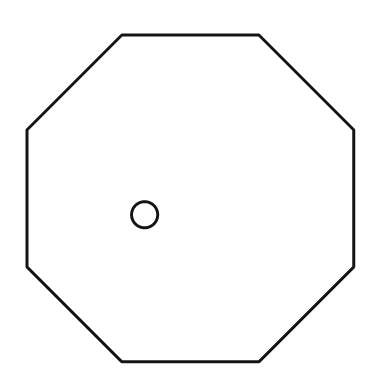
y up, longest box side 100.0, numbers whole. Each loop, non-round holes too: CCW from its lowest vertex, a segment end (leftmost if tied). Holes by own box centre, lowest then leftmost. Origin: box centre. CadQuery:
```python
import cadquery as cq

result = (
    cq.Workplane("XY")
    .moveTo(-21.0, -50.0)
    .lineTo(21.0, -50.0)
    .lineTo(50.0, -21.0)
    .lineTo(50.0, 21.0)
    .lineTo(21.0, 50.0)
    .lineTo(-21.0, 50.0)
    .lineTo(-50.0, 21.0)
    .lineTo(-50.0, -21.0)
    .close()
    .moveTo(-14.0, -5.0)
    .circle(4.0)
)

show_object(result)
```